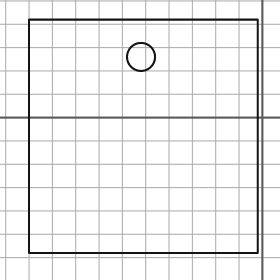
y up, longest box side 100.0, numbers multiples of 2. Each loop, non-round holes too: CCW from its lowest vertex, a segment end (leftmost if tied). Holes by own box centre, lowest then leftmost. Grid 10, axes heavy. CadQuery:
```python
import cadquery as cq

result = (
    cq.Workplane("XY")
    .moveTo(-100.0, -58.0)
    .lineTo(-2.0, -58.0)
    .lineTo(-2.0, 42.0)
    .lineTo(-100.0, 42.0)
    .close()
    .moveTo(-52.0, 26.0)
    .circle(6.0)
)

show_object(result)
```